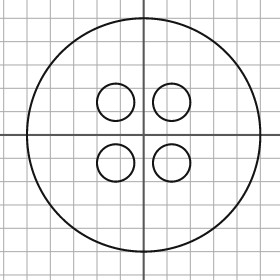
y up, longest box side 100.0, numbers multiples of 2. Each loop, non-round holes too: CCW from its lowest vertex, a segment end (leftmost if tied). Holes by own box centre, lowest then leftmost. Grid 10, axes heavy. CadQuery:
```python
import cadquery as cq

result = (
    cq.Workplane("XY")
    .moveTo(0.0, 0.0)
    .circle(50.0)
    .moveTo(-12.0, -12.0)
    .circle(8.0)
    .moveTo(12.0, -12.0)
    .circle(8.0)
    .moveTo(-12.0, 14.0)
    .circle(8.0)
    .moveTo(12.0, 14.0)
    .circle(8.0)
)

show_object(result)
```